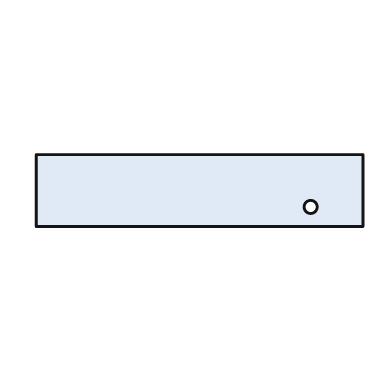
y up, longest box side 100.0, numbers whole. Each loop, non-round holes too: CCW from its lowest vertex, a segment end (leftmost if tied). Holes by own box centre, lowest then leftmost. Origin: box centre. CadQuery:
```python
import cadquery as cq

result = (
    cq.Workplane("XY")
    .moveTo(-50.0, -11.0)
    .lineTo(50.0, -11.0)
    .lineTo(50.0, 11.0)
    .lineTo(-50.0, 11.0)
    .close()
    .moveTo(34.0, -5.0)
    .circle(2.0)
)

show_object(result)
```